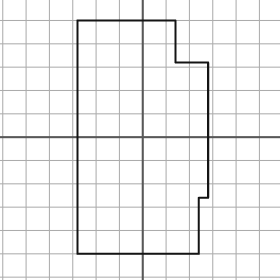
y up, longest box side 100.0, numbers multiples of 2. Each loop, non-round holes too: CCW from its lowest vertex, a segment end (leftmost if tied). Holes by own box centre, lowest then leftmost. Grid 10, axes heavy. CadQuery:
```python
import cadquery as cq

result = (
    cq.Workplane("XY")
    .moveTo(-28.0, -50.0)
    .lineTo(24.0, -50.0)
    .lineTo(24.0, -26.0)
    .lineTo(28.0, -26.0)
    .lineTo(28.0, 32.0)
    .lineTo(14.0, 32.0)
    .lineTo(14.0, 50.0)
    .lineTo(-28.0, 50.0)
    .close()
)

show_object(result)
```